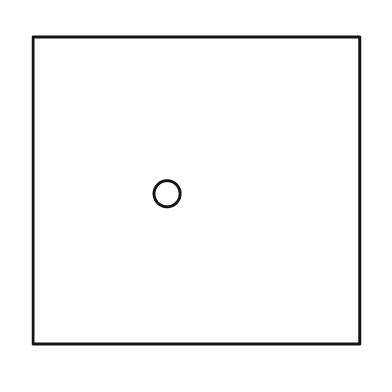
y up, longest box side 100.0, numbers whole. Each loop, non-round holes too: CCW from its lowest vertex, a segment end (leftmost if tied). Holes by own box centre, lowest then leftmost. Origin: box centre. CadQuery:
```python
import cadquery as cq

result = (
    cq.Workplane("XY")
    .moveTo(-50.0, -47.0)
    .lineTo(50.0, -47.0)
    .lineTo(50.0, 47.0)
    .lineTo(-50.0, 47.0)
    .close()
    .moveTo(-9.0, -1.0)
    .circle(4.0)
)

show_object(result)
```